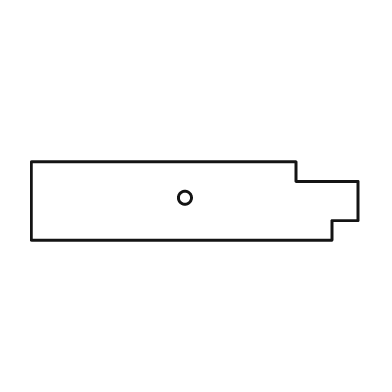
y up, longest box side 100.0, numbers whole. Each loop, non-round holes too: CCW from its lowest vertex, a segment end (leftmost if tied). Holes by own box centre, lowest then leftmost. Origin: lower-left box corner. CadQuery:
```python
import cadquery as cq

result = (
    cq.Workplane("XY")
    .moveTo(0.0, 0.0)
    .lineTo(92.0, 0.0)
    .lineTo(92.0, 6.0)
    .lineTo(100.0, 6.0)
    .lineTo(100.0, 18.0)
    .lineTo(81.0, 18.0)
    .lineTo(81.0, 24.0)
    .lineTo(0.0, 24.0)
    .close()
    .moveTo(47.0, 13.0)
    .circle(2.0)
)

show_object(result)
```